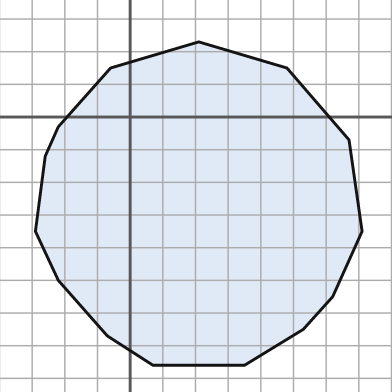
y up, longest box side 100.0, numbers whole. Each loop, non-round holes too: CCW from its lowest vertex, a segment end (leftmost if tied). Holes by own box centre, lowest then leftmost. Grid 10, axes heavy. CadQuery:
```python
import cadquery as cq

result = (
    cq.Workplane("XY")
    .moveTo(7.0, -76.0)
    .lineTo(35.0, -76.0)
    .lineTo(53.0, -65.0)
    .lineTo(62.0, -55.0)
    .lineTo(71.0, -35.0)
    .lineTo(67.0, -7.0)
    .lineTo(48.0, 15.0)
    .lineTo(21.0, 23.0)
    .lineTo(-6.0, 15.0)
    .lineTo(-22.0, -3.0)
    .lineTo(-26.0, -12.0)
    .lineTo(-29.0, -35.0)
    .lineTo(-22.0, -50.0)
    .lineTo(-7.0, -67.0)
    .close()
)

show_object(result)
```